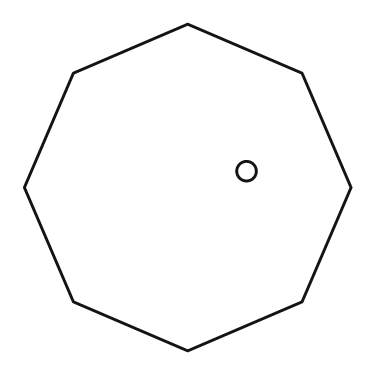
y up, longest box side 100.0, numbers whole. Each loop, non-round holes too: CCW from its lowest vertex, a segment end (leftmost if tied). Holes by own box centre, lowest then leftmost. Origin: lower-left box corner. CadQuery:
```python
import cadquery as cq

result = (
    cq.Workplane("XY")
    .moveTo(50.0, 0.0)
    .lineTo(85.0, 15.0)
    .lineTo(100.0, 50.0)
    .lineTo(85.0, 85.0)
    .lineTo(50.0, 100.0)
    .lineTo(15.0, 85.0)
    .lineTo(0.0, 50.0)
    .lineTo(15.0, 15.0)
    .close()
    .moveTo(68.0, 55.0)
    .circle(3.0)
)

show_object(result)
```